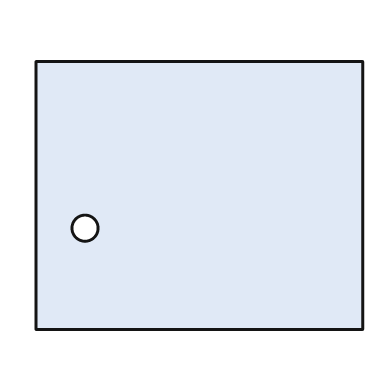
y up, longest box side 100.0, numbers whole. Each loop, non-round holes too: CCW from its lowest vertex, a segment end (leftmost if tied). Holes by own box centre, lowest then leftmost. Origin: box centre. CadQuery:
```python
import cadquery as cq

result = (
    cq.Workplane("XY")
    .moveTo(-50.0, -41.0)
    .lineTo(50.0, -41.0)
    .lineTo(50.0, 41.0)
    .lineTo(-50.0, 41.0)
    .close()
    .moveTo(-35.0, -10.0)
    .circle(4.0)
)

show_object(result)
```